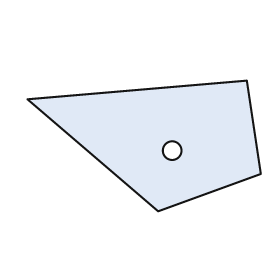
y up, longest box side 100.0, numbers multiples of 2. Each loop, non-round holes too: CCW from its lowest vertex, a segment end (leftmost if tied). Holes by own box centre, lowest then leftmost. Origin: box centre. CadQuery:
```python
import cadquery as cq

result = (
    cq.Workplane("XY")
    .moveTo(6.0, -28.0)
    .lineTo(50.0, -12.0)
    .lineTo(44.0, 28.0)
    .lineTo(-50.0, 20.0)
    .close()
    .moveTo(12.0, -2.0)
    .circle(4.0)
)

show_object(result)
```